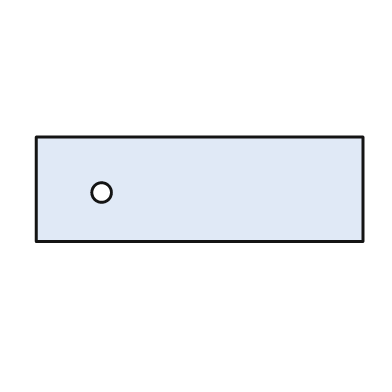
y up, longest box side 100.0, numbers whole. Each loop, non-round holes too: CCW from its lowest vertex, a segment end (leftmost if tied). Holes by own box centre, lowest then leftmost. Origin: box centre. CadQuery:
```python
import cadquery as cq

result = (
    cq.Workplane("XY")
    .moveTo(-50.0, -16.0)
    .lineTo(50.0, -16.0)
    .lineTo(50.0, 16.0)
    .lineTo(-50.0, 16.0)
    .close()
    .moveTo(-30.0, -1.0)
    .circle(3.0)
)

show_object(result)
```